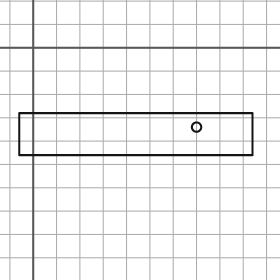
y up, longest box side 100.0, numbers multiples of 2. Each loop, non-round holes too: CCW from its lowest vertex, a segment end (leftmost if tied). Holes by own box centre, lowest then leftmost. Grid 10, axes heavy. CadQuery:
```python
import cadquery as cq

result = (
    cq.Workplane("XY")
    .moveTo(-6.0, -46.0)
    .lineTo(94.0, -46.0)
    .lineTo(94.0, -28.0)
    .lineTo(-6.0, -28.0)
    .close()
    .moveTo(70.0, -34.0)
    .circle(2.0)
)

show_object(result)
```